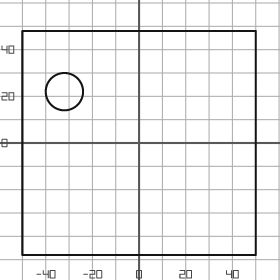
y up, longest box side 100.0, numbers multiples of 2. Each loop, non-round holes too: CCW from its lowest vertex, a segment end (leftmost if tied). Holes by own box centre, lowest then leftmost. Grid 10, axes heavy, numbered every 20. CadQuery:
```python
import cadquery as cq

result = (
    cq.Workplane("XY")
    .moveTo(-50.0, -48.0)
    .lineTo(50.0, -48.0)
    .lineTo(50.0, 48.0)
    .lineTo(-50.0, 48.0)
    .close()
    .moveTo(-32.0, 22.0)
    .circle(8.0)
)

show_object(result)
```